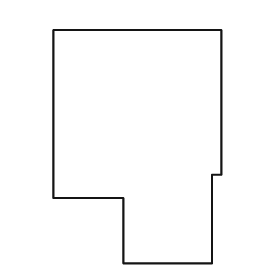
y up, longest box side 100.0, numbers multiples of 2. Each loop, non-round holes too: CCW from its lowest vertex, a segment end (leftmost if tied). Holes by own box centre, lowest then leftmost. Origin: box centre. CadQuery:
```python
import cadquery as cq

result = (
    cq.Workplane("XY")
    .moveTo(-6.0, -50.0)
    .lineTo(32.0, -50.0)
    .lineTo(32.0, -12.0)
    .lineTo(36.0, -12.0)
    .lineTo(36.0, 50.0)
    .lineTo(-36.0, 50.0)
    .lineTo(-36.0, -22.0)
    .lineTo(-6.0, -22.0)
    .close()
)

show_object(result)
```